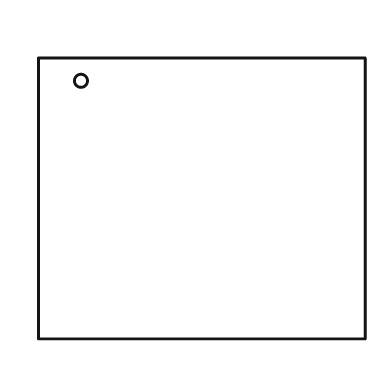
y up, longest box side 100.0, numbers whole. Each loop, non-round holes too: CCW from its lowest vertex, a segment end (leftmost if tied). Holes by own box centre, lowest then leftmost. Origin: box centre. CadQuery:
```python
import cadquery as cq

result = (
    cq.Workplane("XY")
    .moveTo(-50.0, -43.0)
    .lineTo(50.0, -43.0)
    .lineTo(50.0, 43.0)
    .lineTo(-50.0, 43.0)
    .close()
    .moveTo(-37.0, 36.0)
    .circle(2.0)
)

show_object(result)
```